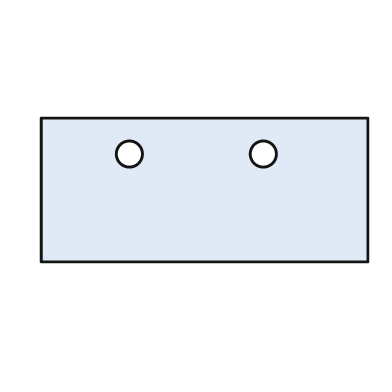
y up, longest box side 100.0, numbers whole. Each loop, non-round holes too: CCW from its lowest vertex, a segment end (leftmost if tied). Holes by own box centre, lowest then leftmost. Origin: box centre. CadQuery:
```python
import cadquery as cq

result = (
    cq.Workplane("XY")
    .moveTo(-50.0, -22.0)
    .lineTo(50.0, -22.0)
    .lineTo(50.0, 22.0)
    .lineTo(-50.0, 22.0)
    .close()
    .moveTo(-23.0, 11.0)
    .circle(4.0)
    .moveTo(18.0, 11.0)
    .circle(4.0)
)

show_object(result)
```